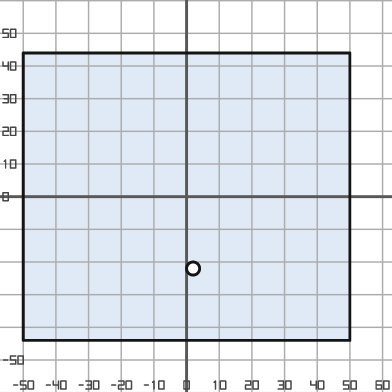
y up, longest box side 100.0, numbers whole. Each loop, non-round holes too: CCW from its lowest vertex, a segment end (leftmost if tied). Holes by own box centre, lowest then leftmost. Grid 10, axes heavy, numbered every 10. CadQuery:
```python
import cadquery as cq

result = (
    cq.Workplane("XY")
    .moveTo(-50.0, -44.0)
    .lineTo(50.0, -44.0)
    .lineTo(50.0, 44.0)
    .lineTo(-50.0, 44.0)
    .close()
    .moveTo(2.0, -22.0)
    .circle(2.0)
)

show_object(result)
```